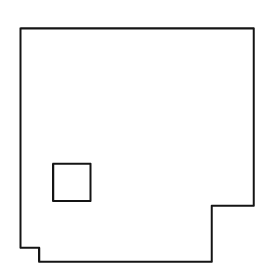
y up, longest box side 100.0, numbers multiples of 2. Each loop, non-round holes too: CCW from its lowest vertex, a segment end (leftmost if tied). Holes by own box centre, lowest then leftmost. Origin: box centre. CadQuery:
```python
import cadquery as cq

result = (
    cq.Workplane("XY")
    .moveTo(-42.0, -50.0)
    .lineTo(32.0, -50.0)
    .lineTo(32.0, -26.0)
    .lineTo(50.0, -26.0)
    .lineTo(50.0, 50.0)
    .lineTo(-50.0, 50.0)
    .lineTo(-50.0, -44.0)
    .lineTo(-42.0, -44.0)
    .close()
    .moveTo(-36.0, -24.0)
    .lineTo(-20.0, -24.0)
    .lineTo(-20.0, -8.0)
    .lineTo(-36.0, -8.0)
    .close()
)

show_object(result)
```